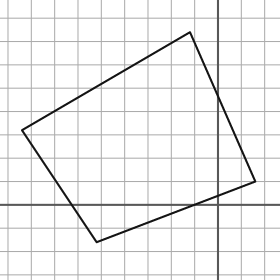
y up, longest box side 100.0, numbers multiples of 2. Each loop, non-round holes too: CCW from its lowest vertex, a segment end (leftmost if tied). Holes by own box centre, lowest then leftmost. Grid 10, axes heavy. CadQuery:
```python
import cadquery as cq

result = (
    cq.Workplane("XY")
    .moveTo(-52.0, -16.0)
    .lineTo(16.0, 10.0)
    .lineTo(-12.0, 74.0)
    .lineTo(-84.0, 32.0)
    .close()
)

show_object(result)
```